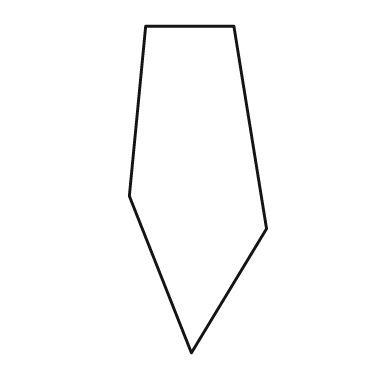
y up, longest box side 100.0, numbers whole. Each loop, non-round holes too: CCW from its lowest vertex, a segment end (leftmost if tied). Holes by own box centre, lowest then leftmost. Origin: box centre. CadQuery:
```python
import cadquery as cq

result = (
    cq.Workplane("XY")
    .moveTo(-2.0, -50.0)
    .lineTo(21.0, -12.0)
    .lineTo(11.0, 50.0)
    .lineTo(-16.0, 50.0)
    .lineTo(-21.0, -2.0)
    .close()
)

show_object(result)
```